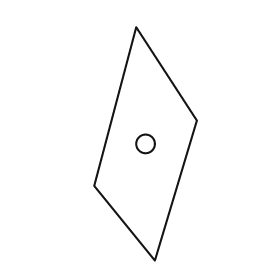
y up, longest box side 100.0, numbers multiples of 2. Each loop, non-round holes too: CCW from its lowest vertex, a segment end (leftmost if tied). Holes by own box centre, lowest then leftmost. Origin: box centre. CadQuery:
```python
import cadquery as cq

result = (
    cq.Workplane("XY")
    .moveTo(4.0, -50.0)
    .lineTo(22.0, 10.0)
    .lineTo(-4.0, 50.0)
    .lineTo(-22.0, -18.0)
    .close()
    .moveTo(0.0, 0.0)
    .circle(4.0)
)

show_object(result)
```